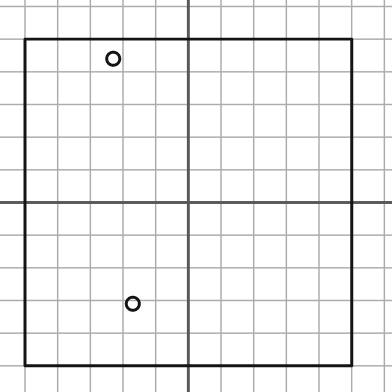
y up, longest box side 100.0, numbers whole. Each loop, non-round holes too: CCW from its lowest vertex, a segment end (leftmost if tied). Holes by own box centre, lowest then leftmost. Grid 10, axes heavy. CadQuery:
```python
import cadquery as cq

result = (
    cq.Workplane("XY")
    .moveTo(-50.0, -50.0)
    .lineTo(50.0, -50.0)
    .lineTo(50.0, 50.0)
    .lineTo(-50.0, 50.0)
    .close()
    .moveTo(-17.0, -31.0)
    .circle(2.0)
    .moveTo(-23.0, 44.0)
    .circle(2.0)
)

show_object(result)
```